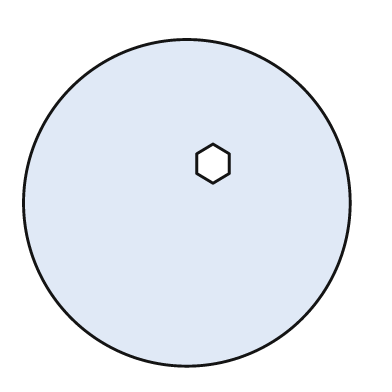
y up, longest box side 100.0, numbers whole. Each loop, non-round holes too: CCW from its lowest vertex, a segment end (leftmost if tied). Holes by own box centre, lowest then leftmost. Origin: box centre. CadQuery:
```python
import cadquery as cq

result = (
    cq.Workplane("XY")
    .moveTo(0.0, 0.0)
    .circle(50.0)
    .moveTo(8.0, 6.0)
    .lineTo(13.0, 9.0)
    .lineTo(13.0, 15.0)
    .lineTo(8.0, 18.0)
    .lineTo(3.0, 15.0)
    .lineTo(3.0, 9.0)
    .close()
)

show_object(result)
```